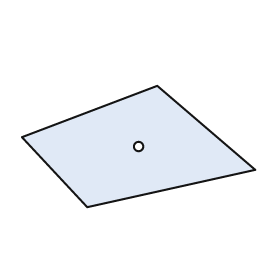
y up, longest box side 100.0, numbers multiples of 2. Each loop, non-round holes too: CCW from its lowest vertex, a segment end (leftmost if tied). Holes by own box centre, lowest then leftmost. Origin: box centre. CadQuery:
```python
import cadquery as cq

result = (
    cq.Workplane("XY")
    .moveTo(-22.0, -26.0)
    .lineTo(50.0, -10.0)
    .lineTo(8.0, 26.0)
    .lineTo(-50.0, 4.0)
    .close()
    .moveTo(0.0, 0.0)
    .circle(2.0)
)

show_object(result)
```